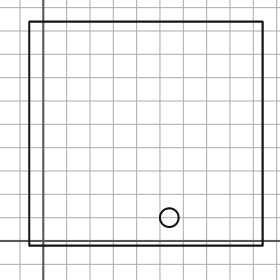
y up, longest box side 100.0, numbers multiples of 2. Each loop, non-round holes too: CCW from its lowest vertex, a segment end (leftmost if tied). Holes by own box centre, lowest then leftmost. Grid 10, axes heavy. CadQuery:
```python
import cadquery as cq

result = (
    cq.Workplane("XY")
    .moveTo(-6.0, -2.0)
    .lineTo(94.0, -2.0)
    .lineTo(94.0, 94.0)
    .lineTo(-6.0, 94.0)
    .close()
    .moveTo(54.0, 10.0)
    .circle(4.0)
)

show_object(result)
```